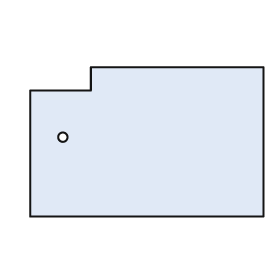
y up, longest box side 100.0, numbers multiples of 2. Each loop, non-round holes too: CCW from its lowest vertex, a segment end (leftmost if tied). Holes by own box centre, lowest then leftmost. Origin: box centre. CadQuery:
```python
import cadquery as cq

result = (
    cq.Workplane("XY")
    .moveTo(-50.0, -32.0)
    .lineTo(50.0, -32.0)
    .lineTo(50.0, 32.0)
    .lineTo(-24.0, 32.0)
    .lineTo(-24.0, 22.0)
    .lineTo(-50.0, 22.0)
    .close()
    .moveTo(-36.0, 2.0)
    .circle(2.0)
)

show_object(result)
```